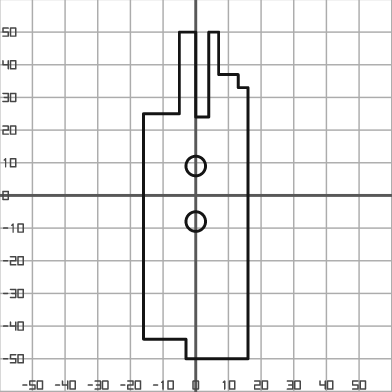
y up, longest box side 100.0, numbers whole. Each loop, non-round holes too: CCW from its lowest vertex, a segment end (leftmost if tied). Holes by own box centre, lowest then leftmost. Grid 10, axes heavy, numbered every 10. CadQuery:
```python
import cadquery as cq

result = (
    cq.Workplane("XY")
    .moveTo(-3.0, -50.0)
    .lineTo(16.0, -50.0)
    .lineTo(16.0, 33.0)
    .lineTo(13.0, 33.0)
    .lineTo(13.0, 37.0)
    .lineTo(7.0, 37.0)
    .lineTo(7.0, 50.0)
    .lineTo(4.0, 50.0)
    .lineTo(4.0, 24.0)
    .lineTo(0.0, 24.0)
    .lineTo(0.0, 50.0)
    .lineTo(-5.0, 50.0)
    .lineTo(-5.0, 25.0)
    .lineTo(-16.0, 25.0)
    .lineTo(-16.0, -44.0)
    .lineTo(-3.0, -44.0)
    .close()
    .moveTo(0.0, -8.0)
    .circle(3.0)
    .moveTo(0.0, 9.0)
    .circle(3.0)
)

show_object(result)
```